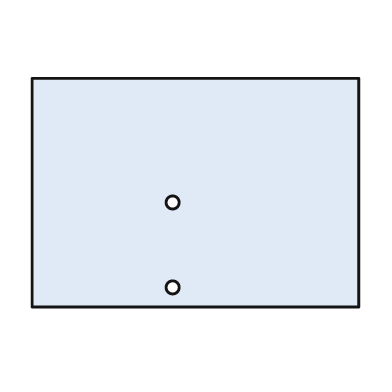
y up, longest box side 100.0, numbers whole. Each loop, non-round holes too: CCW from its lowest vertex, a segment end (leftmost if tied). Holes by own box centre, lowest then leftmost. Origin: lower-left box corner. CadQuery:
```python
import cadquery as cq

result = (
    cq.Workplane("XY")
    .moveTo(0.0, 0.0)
    .lineTo(100.0, 0.0)
    .lineTo(100.0, 70.0)
    .lineTo(0.0, 70.0)
    .close()
    .moveTo(43.0, 6.0)
    .circle(2.0)
    .moveTo(43.0, 32.0)
    .circle(2.0)
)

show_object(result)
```